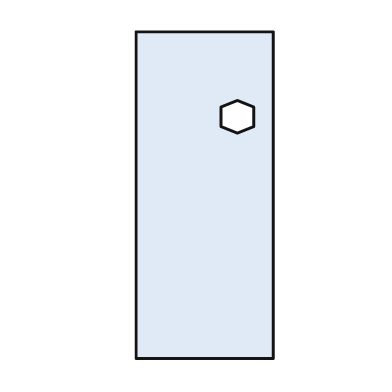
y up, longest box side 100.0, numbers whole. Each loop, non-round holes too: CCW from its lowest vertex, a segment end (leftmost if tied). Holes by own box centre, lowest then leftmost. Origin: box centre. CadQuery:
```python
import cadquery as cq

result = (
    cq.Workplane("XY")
    .moveTo(-21.0, -50.0)
    .lineTo(21.0, -50.0)
    .lineTo(21.0, 50.0)
    .lineTo(-21.0, 50.0)
    .close()
    .moveTo(10.0, 19.0)
    .lineTo(15.0, 21.0)
    .lineTo(15.0, 27.0)
    .lineTo(10.0, 29.0)
    .lineTo(5.0, 27.0)
    .lineTo(5.0, 21.0)
    .close()
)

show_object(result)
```